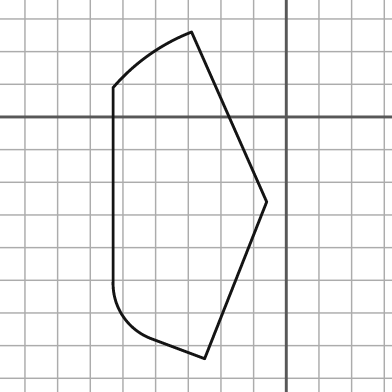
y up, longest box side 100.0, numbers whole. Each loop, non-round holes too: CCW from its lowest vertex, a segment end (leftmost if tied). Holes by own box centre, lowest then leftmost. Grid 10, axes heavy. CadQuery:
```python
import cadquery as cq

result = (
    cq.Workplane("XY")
    .moveTo(-25.0, -74.0)
    .lineTo(-6.0, -26.0)
    .lineTo(-29.0, 26.0)
    .threePointArc((-42.0, 19.0), (-53.0, 9.0))
    .lineTo(-53.0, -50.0)
    .threePointArc((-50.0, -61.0), (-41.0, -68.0))
    .close()
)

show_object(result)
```